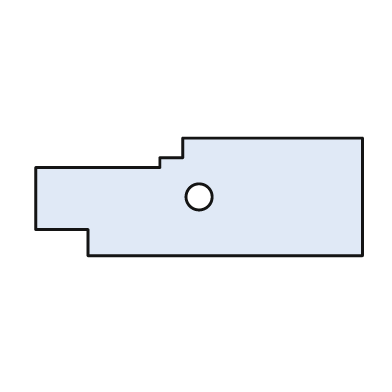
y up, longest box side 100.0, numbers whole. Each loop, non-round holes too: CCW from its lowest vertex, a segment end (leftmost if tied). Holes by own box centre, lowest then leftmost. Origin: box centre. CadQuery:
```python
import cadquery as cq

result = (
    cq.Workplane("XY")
    .moveTo(-34.0, -18.0)
    .lineTo(50.0, -18.0)
    .lineTo(50.0, 18.0)
    .lineTo(-5.0, 18.0)
    .lineTo(-5.0, 12.0)
    .lineTo(-12.0, 12.0)
    .lineTo(-12.0, 9.0)
    .lineTo(-50.0, 9.0)
    .lineTo(-50.0, -10.0)
    .lineTo(-34.0, -10.0)
    .close()
    .moveTo(0.0, 0.0)
    .circle(4.0)
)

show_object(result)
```